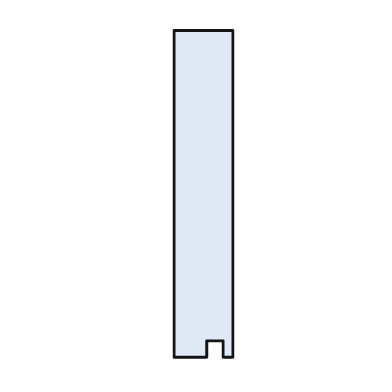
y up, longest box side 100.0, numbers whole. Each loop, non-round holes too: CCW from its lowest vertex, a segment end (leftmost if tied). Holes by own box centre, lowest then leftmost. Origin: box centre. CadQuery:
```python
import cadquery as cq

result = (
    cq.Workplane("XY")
    .moveTo(-9.0, -50.0)
    .lineTo(1.0, -50.0)
    .lineTo(1.0, -45.0)
    .lineTo(6.0, -45.0)
    .lineTo(6.0, -50.0)
    .lineTo(9.0, -50.0)
    .lineTo(9.0, 50.0)
    .lineTo(-9.0, 50.0)
    .close()
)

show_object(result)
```